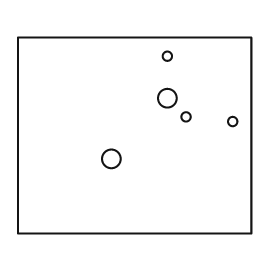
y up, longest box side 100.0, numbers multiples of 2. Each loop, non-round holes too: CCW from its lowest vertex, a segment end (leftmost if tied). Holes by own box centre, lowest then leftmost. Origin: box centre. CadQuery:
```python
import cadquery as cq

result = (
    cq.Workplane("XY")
    .moveTo(-50.0, -42.0)
    .lineTo(50.0, -42.0)
    .lineTo(50.0, 42.0)
    .lineTo(-50.0, 42.0)
    .close()
    .moveTo(-10.0, -10.0)
    .circle(4.0)
    .moveTo(42.0, 6.0)
    .circle(2.0)
    .moveTo(22.0, 8.0)
    .circle(2.0)
    .moveTo(14.0, 16.0)
    .circle(4.0)
    .moveTo(14.0, 34.0)
    .circle(2.0)
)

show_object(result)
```